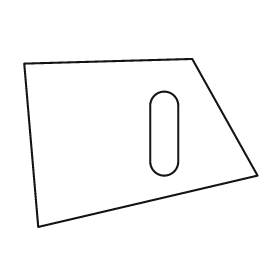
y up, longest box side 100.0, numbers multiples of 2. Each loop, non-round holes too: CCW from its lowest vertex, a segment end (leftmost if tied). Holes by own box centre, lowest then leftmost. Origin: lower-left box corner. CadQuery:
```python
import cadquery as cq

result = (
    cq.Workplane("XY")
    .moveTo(6.0, 0.0)
    .lineTo(100.0, 22.0)
    .lineTo(72.0, 72.0)
    .lineTo(0.0, 70.0)
    .close()
    .moveTo(54.0, 28.0)
    .threePointArc((60.0, 22.0), (66.0, 28.0))
    .lineTo(66.0, 52.0)
    .threePointArc((60.0, 58.0), (54.0, 52.0))
    .close()
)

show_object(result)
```